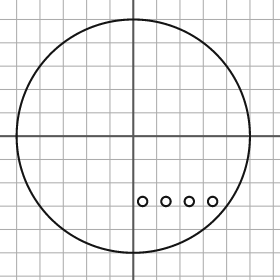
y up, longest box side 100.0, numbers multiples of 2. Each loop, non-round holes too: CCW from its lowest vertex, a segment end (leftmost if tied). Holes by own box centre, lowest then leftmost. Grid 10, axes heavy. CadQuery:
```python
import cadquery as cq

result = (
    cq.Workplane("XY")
    .moveTo(0.0, 0.0)
    .circle(50.0)
    .moveTo(4.0, -28.0)
    .circle(2.0)
    .moveTo(14.0, -28.0)
    .circle(2.0)
    .moveTo(24.0, -28.0)
    .circle(2.0)
    .moveTo(34.0, -28.0)
    .circle(2.0)
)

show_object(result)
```